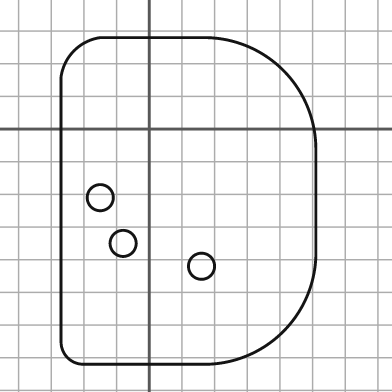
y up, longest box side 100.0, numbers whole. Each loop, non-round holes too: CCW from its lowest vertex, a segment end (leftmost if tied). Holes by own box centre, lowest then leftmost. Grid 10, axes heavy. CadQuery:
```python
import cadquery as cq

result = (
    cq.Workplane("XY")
    .moveTo(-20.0, -72.0)
    .lineTo(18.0, -72.0)
    .threePointArc((41.0, -62.0), (51.0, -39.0))
    .lineTo(51.0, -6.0)
    .threePointArc((41.0, 18.0), (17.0, 28.0))
    .lineTo(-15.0, 28.0)
    .threePointArc((-23.0, 24.0), (-27.0, 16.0))
    .lineTo(-27.0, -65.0)
    .threePointArc((-25.0, -70.0), (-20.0, -72.0))
    .close()
    .moveTo(16.0, -42.0)
    .circle(4.0)
    .moveTo(-8.0, -35.0)
    .circle(4.0)
    .moveTo(-15.0, -21.0)
    .circle(4.0)
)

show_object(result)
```